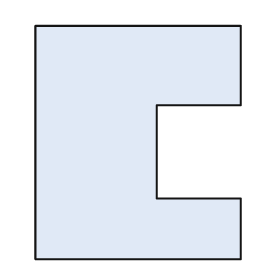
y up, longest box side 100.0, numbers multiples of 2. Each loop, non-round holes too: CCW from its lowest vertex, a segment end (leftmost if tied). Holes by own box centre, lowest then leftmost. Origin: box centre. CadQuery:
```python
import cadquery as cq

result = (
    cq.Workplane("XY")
    .moveTo(-44.0, -50.0)
    .lineTo(44.0, -50.0)
    .lineTo(44.0, -24.0)
    .lineTo(8.0, -24.0)
    .lineTo(8.0, 16.0)
    .lineTo(44.0, 16.0)
    .lineTo(44.0, 50.0)
    .lineTo(-44.0, 50.0)
    .close()
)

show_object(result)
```